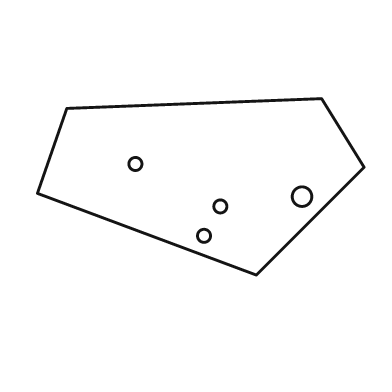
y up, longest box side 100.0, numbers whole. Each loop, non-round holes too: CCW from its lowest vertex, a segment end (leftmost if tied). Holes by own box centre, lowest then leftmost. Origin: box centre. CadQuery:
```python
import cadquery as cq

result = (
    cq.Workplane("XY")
    .moveTo(17.0, -27.0)
    .lineTo(50.0, 6.0)
    .lineTo(37.0, 27.0)
    .lineTo(-41.0, 24.0)
    .lineTo(-50.0, -2.0)
    .close()
    .moveTo(1.0, -15.0)
    .circle(2.0)
    .moveTo(6.0, -6.0)
    .circle(2.0)
    .moveTo(31.0, -3.0)
    .circle(3.0)
    .moveTo(-20.0, 7.0)
    .circle(2.0)
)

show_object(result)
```